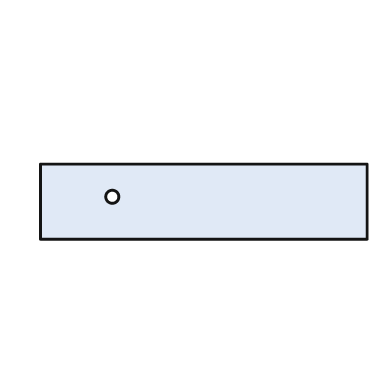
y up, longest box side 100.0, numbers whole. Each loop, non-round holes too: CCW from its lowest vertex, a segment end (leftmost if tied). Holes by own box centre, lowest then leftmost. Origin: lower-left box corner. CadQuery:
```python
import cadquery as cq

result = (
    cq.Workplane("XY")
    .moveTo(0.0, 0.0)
    .lineTo(100.0, 0.0)
    .lineTo(100.0, 23.0)
    .lineTo(0.0, 23.0)
    .close()
    .moveTo(22.0, 13.0)
    .circle(2.0)
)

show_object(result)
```